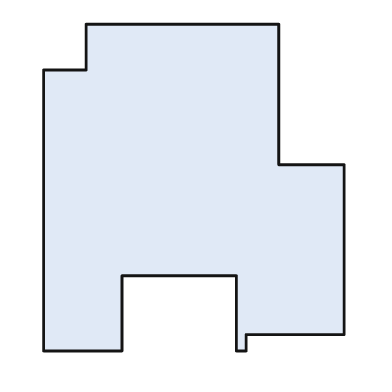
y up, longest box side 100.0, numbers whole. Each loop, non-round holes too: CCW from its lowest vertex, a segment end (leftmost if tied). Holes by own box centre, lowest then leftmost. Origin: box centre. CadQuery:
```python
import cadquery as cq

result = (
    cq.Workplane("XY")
    .moveTo(-46.0, -50.0)
    .lineTo(-22.0, -50.0)
    .lineTo(-22.0, -27.0)
    .lineTo(13.0, -27.0)
    .lineTo(13.0, -50.0)
    .lineTo(16.0, -50.0)
    .lineTo(16.0, -45.0)
    .lineTo(46.0, -45.0)
    .lineTo(46.0, 7.0)
    .lineTo(26.0, 7.0)
    .lineTo(26.0, 50.0)
    .lineTo(-33.0, 50.0)
    .lineTo(-33.0, 36.0)
    .lineTo(-46.0, 36.0)
    .close()
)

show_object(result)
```